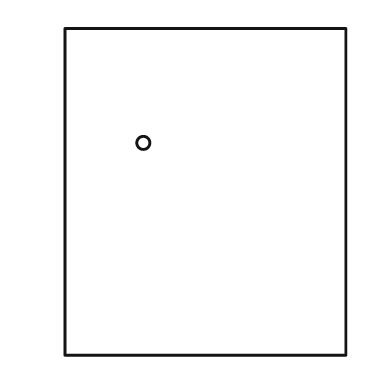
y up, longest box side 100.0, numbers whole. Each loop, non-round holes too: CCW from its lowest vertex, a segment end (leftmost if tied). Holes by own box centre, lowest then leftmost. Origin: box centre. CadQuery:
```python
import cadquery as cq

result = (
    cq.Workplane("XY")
    .moveTo(-43.0, -50.0)
    .lineTo(43.0, -50.0)
    .lineTo(43.0, 50.0)
    .lineTo(-43.0, 50.0)
    .close()
    .moveTo(-19.0, 15.0)
    .circle(2.0)
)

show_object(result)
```